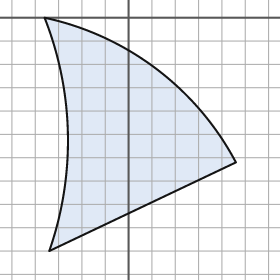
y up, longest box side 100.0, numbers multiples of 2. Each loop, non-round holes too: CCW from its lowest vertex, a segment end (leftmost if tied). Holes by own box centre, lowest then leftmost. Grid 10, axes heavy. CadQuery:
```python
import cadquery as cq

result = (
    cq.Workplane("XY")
    .moveTo(-34.0, -100.0)
    .lineTo(46.0, -62.0)
    .threePointArc((12.0, -22.0), (-36.0, 0.0))
    .threePointArc((-26.0, -50.0), (-34.0, -100.0))
    .close()
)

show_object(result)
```